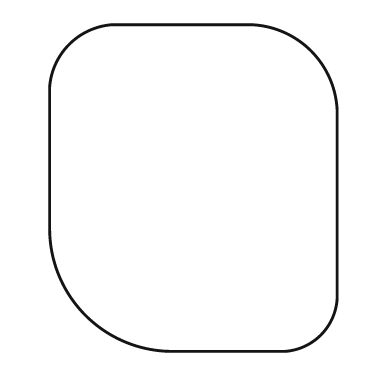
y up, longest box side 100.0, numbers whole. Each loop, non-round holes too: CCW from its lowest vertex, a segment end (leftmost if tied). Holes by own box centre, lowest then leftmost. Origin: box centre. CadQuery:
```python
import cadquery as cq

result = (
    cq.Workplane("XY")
    .moveTo(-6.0, -50.0)
    .lineTo(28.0, -50.0)
    .threePointArc((39.0, -45.0), (44.0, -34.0))
    .lineTo(44.0, 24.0)
    .threePointArc((36.0, 42.0), (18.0, 50.0))
    .lineTo(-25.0, 50.0)
    .threePointArc((-38.0, 44.0), (-44.0, 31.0))
    .lineTo(-44.0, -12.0)
    .threePointArc((-33.0, -39.0), (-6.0, -50.0))
    .close()
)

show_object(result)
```